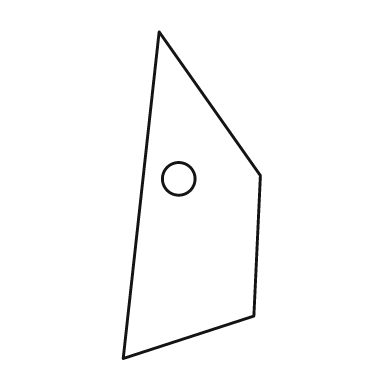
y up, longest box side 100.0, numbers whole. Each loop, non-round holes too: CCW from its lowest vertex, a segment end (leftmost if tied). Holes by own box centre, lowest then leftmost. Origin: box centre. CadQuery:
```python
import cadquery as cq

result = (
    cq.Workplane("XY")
    .moveTo(-21.0, -50.0)
    .lineTo(19.0, -37.0)
    .lineTo(21.0, 6.0)
    .lineTo(-10.0, 50.0)
    .close()
    .moveTo(-4.0, 5.0)
    .circle(5.0)
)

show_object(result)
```